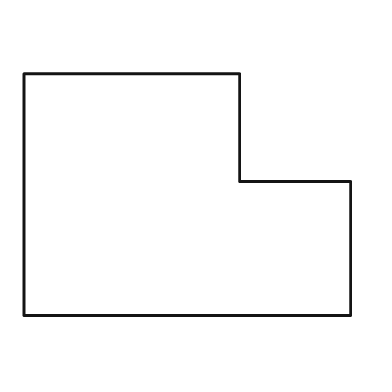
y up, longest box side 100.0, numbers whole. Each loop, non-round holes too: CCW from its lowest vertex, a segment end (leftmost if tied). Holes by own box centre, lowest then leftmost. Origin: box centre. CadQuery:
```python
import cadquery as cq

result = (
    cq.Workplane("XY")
    .moveTo(-50.0, -37.0)
    .lineTo(50.0, -37.0)
    .lineTo(50.0, 4.0)
    .lineTo(16.0, 4.0)
    .lineTo(16.0, 37.0)
    .lineTo(-50.0, 37.0)
    .close()
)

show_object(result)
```